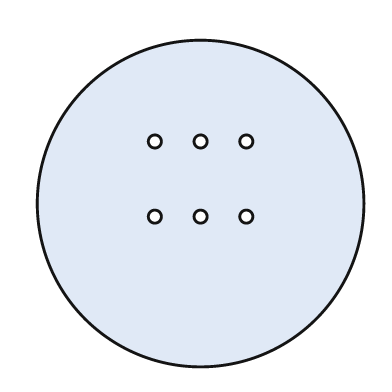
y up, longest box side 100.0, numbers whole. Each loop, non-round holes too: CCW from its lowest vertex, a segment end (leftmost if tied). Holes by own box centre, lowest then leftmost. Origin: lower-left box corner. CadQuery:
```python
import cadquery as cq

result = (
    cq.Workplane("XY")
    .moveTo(50.0, 50.0)
    .circle(50.0)
    .moveTo(36.0, 46.0)
    .circle(2.0)
    .moveTo(50.0, 46.0)
    .circle(2.0)
    .moveTo(64.0, 46.0)
    .circle(2.0)
    .moveTo(36.0, 69.0)
    .circle(2.0)
    .moveTo(50.0, 69.0)
    .circle(2.0)
    .moveTo(64.0, 69.0)
    .circle(2.0)
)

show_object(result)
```